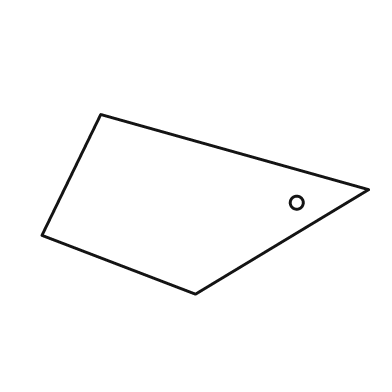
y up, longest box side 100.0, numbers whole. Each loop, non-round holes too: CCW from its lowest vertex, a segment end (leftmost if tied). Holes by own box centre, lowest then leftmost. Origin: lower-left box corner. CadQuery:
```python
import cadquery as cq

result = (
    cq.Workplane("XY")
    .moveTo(47.0, 0.0)
    .lineTo(100.0, 32.0)
    .lineTo(18.0, 55.0)
    .lineTo(0.0, 18.0)
    .close()
    .moveTo(78.0, 28.0)
    .circle(2.0)
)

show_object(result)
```